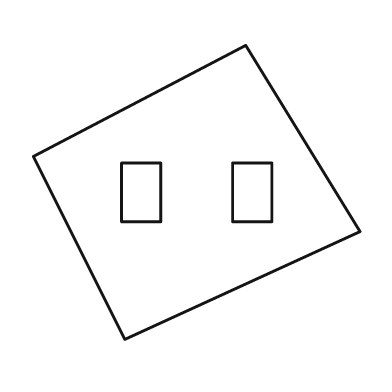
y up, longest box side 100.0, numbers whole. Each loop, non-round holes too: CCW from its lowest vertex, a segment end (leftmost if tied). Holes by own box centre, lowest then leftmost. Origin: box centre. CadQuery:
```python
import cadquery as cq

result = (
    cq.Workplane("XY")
    .moveTo(-22.0, -45.0)
    .lineTo(50.0, -12.0)
    .lineTo(15.0, 45.0)
    .lineTo(-50.0, 11.0)
    .close()
    .moveTo(-23.0, -9.0)
    .lineTo(-11.0, -9.0)
    .lineTo(-11.0, 9.0)
    .lineTo(-23.0, 9.0)
    .close()
    .moveTo(11.0, -9.0)
    .lineTo(23.0, -9.0)
    .lineTo(23.0, 9.0)
    .lineTo(11.0, 9.0)
    .close()
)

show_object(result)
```